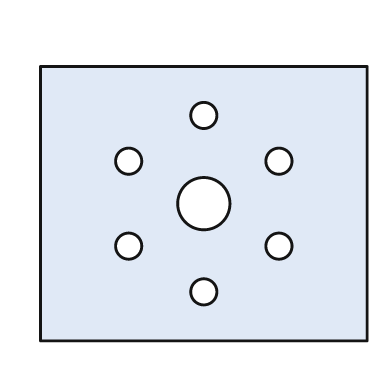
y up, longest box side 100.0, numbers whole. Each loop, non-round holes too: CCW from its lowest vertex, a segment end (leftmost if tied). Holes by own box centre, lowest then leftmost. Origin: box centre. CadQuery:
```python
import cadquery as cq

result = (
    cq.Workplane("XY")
    .moveTo(-50.0, -42.0)
    .lineTo(50.0, -42.0)
    .lineTo(50.0, 42.0)
    .lineTo(-50.0, 42.0)
    .close()
    .moveTo(0.0, -27.0)
    .circle(4.0)
    .moveTo(-23.0, -13.0)
    .circle(4.0)
    .moveTo(23.0, -13.0)
    .circle(4.0)
    .moveTo(0.0, 0.0)
    .circle(8.0)
    .moveTo(-23.0, 13.0)
    .circle(4.0)
    .moveTo(23.0, 13.0)
    .circle(4.0)
    .moveTo(0.0, 27.0)
    .circle(4.0)
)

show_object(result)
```